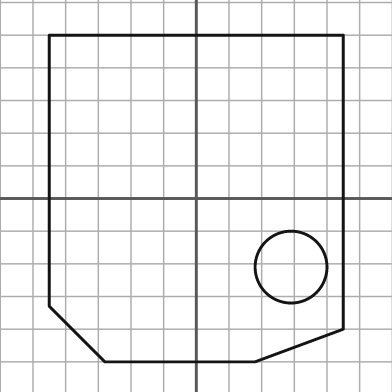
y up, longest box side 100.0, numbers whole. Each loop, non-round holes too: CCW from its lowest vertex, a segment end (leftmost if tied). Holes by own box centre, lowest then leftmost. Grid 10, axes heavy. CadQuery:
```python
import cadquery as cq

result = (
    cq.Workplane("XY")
    .moveTo(-28.0, -50.0)
    .lineTo(18.0, -50.0)
    .lineTo(45.0, -40.0)
    .lineTo(45.0, 50.0)
    .lineTo(-45.0, 50.0)
    .lineTo(-45.0, -33.0)
    .close()
    .moveTo(29.0, -21.0)
    .circle(11.0)
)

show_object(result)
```